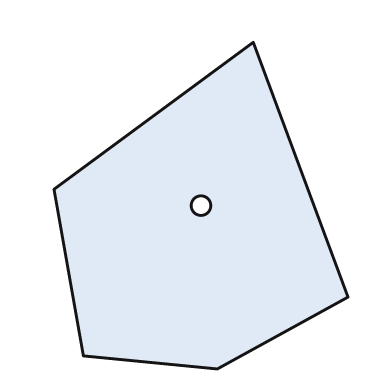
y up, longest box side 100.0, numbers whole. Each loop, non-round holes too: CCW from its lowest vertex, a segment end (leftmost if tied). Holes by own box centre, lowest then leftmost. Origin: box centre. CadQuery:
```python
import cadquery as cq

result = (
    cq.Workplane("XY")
    .moveTo(5.0, -50.0)
    .lineTo(45.0, -28.0)
    .lineTo(16.0, 50.0)
    .lineTo(-45.0, 5.0)
    .lineTo(-36.0, -46.0)
    .close()
    .moveTo(0.0, 0.0)
    .circle(3.0)
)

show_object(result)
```